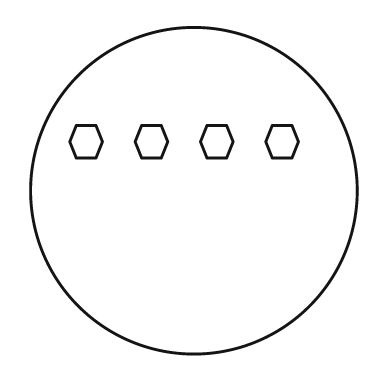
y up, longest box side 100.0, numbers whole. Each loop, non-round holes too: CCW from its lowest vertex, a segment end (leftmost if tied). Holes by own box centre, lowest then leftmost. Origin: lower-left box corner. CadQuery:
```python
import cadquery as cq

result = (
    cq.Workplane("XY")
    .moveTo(50.0, 50.0)
    .circle(50.0)
    .moveTo(14.0, 60.0)
    .lineTo(20.0, 60.0)
    .lineTo(22.0, 65.0)
    .lineTo(20.0, 70.0)
    .lineTo(14.0, 70.0)
    .lineTo(12.0, 65.0)
    .close()
    .moveTo(34.0, 60.0)
    .lineTo(40.0, 60.0)
    .lineTo(42.0, 65.0)
    .lineTo(40.0, 70.0)
    .lineTo(34.0, 70.0)
    .lineTo(32.0, 65.0)
    .close()
    .moveTo(54.0, 60.0)
    .lineTo(60.0, 60.0)
    .lineTo(62.0, 65.0)
    .lineTo(60.0, 70.0)
    .lineTo(54.0, 70.0)
    .lineTo(52.0, 65.0)
    .close()
    .moveTo(74.0, 60.0)
    .lineTo(80.0, 60.0)
    .lineTo(82.0, 65.0)
    .lineTo(80.0, 70.0)
    .lineTo(74.0, 70.0)
    .lineTo(72.0, 65.0)
    .close()
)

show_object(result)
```